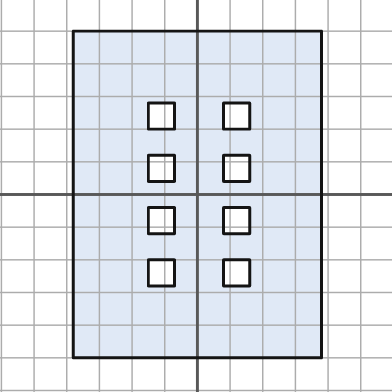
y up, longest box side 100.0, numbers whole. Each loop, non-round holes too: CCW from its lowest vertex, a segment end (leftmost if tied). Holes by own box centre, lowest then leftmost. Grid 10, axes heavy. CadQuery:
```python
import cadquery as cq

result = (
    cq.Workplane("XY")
    .moveTo(-38.0, -50.0)
    .lineTo(38.0, -50.0)
    .lineTo(38.0, 50.0)
    .lineTo(-38.0, 50.0)
    .close()
    .moveTo(-15.0, -28.0)
    .lineTo(-7.0, -28.0)
    .lineTo(-7.0, -20.0)
    .lineTo(-15.0, -20.0)
    .close()
    .moveTo(8.0, -28.0)
    .lineTo(16.0, -28.0)
    .lineTo(16.0, -20.0)
    .lineTo(8.0, -20.0)
    .close()
    .moveTo(-15.0, -12.0)
    .lineTo(-7.0, -12.0)
    .lineTo(-7.0, -4.0)
    .lineTo(-15.0, -4.0)
    .close()
    .moveTo(8.0, -12.0)
    .lineTo(16.0, -12.0)
    .lineTo(16.0, -4.0)
    .lineTo(8.0, -4.0)
    .close()
    .moveTo(-15.0, 4.0)
    .lineTo(-7.0, 4.0)
    .lineTo(-7.0, 12.0)
    .lineTo(-15.0, 12.0)
    .close()
    .moveTo(8.0, 4.0)
    .lineTo(16.0, 4.0)
    .lineTo(16.0, 12.0)
    .lineTo(8.0, 12.0)
    .close()
    .moveTo(-15.0, 20.0)
    .lineTo(-7.0, 20.0)
    .lineTo(-7.0, 28.0)
    .lineTo(-15.0, 28.0)
    .close()
    .moveTo(8.0, 20.0)
    .lineTo(16.0, 20.0)
    .lineTo(16.0, 28.0)
    .lineTo(8.0, 28.0)
    .close()
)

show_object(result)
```